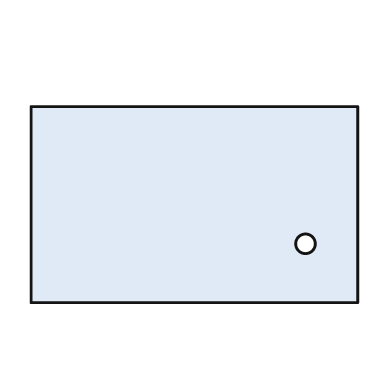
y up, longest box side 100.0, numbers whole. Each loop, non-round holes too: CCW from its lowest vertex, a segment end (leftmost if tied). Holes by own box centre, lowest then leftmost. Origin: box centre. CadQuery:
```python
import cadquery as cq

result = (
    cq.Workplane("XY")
    .moveTo(-50.0, -30.0)
    .lineTo(50.0, -30.0)
    .lineTo(50.0, 30.0)
    .lineTo(-50.0, 30.0)
    .close()
    .moveTo(34.0, -12.0)
    .circle(3.0)
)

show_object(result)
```